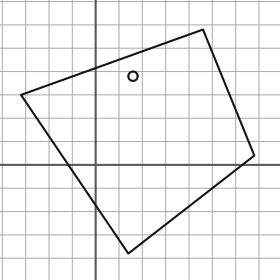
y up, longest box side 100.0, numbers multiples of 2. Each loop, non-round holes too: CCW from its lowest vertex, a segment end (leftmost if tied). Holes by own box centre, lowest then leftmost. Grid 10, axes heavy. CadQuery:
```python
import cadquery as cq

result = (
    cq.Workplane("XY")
    .moveTo(14.0, -38.0)
    .lineTo(68.0, 4.0)
    .lineTo(46.0, 58.0)
    .lineTo(-32.0, 30.0)
    .close()
    .moveTo(16.0, 38.0)
    .circle(2.0)
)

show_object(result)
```